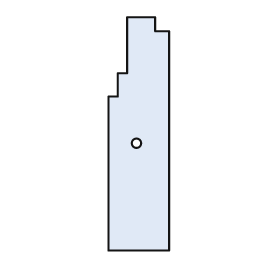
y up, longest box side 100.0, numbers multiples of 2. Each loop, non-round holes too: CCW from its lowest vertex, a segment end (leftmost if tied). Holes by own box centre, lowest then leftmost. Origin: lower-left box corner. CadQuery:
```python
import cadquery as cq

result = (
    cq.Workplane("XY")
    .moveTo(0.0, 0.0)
    .lineTo(26.0, 0.0)
    .lineTo(26.0, 94.0)
    .lineTo(20.0, 94.0)
    .lineTo(20.0, 100.0)
    .lineTo(8.0, 100.0)
    .lineTo(8.0, 76.0)
    .lineTo(4.0, 76.0)
    .lineTo(4.0, 66.0)
    .lineTo(0.0, 66.0)
    .close()
    .moveTo(12.0, 46.0)
    .circle(2.0)
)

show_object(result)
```